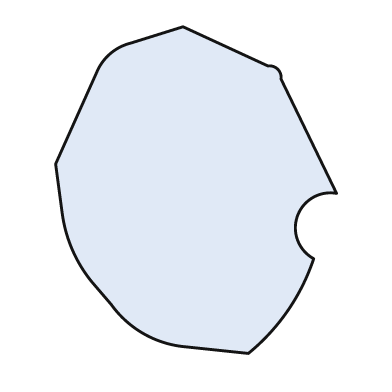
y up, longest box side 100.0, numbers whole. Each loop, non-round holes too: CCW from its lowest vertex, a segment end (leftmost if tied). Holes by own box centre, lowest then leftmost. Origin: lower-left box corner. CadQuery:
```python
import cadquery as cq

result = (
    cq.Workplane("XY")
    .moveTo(59.0, 0.0)
    .threePointArc((71.0, 13.0), (79.0, 29.0))
    .threePointArc((74.0, 42.0), (86.0, 49.0))
    .lineTo(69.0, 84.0)
    .threePointArc((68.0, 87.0), (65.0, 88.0))
    .lineTo(39.0, 100.0)
    .lineTo(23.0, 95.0)
    .threePointArc((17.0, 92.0), (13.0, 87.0))
    .lineTo(0.0, 58.0)
    .lineTo(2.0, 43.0)
    .threePointArc((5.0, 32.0), (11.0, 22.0))
    .lineTo(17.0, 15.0)
    .threePointArc((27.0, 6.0), (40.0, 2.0))
    .close()
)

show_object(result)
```